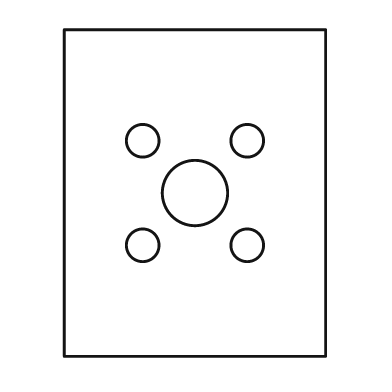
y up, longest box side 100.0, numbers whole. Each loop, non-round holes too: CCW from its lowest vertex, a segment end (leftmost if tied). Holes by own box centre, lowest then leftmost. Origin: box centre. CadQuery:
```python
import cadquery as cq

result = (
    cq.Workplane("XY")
    .moveTo(-40.0, -50.0)
    .lineTo(40.0, -50.0)
    .lineTo(40.0, 50.0)
    .lineTo(-40.0, 50.0)
    .close()
    .moveTo(-16.0, -16.0)
    .circle(5.0)
    .moveTo(16.0, -16.0)
    .circle(5.0)
    .moveTo(0.0, 0.0)
    .circle(10.0)
    .moveTo(-16.0, 16.0)
    .circle(5.0)
    .moveTo(16.0, 16.0)
    .circle(5.0)
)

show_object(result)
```